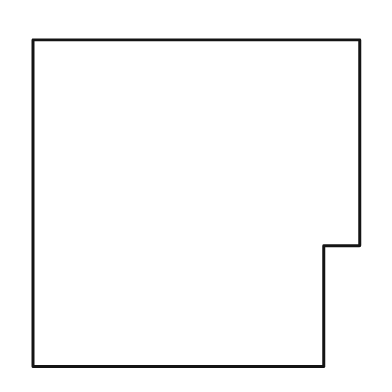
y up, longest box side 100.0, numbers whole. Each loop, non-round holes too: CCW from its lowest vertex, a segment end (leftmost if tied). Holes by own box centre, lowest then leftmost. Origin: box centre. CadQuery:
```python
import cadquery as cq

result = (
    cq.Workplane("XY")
    .moveTo(-50.0, -50.0)
    .lineTo(39.0, -50.0)
    .lineTo(39.0, -13.0)
    .lineTo(50.0, -13.0)
    .lineTo(50.0, 50.0)
    .lineTo(-50.0, 50.0)
    .close()
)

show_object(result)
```